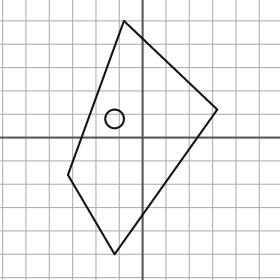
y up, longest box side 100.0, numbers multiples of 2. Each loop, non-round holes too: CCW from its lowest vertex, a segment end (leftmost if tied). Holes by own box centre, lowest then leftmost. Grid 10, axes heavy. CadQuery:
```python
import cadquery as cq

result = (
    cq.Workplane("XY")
    .moveTo(-12.0, -50.0)
    .lineTo(32.0, 12.0)
    .lineTo(-8.0, 50.0)
    .lineTo(-32.0, -16.0)
    .close()
    .moveTo(-12.0, 8.0)
    .circle(4.0)
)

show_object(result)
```